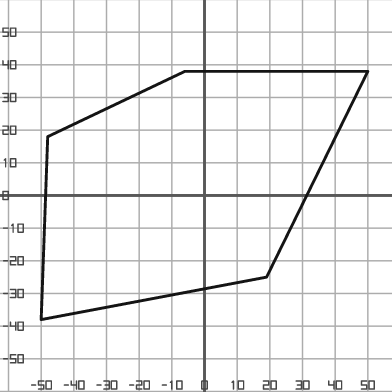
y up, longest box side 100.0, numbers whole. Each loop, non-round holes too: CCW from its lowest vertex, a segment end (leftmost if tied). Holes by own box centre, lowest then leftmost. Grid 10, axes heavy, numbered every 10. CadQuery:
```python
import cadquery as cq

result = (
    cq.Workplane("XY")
    .moveTo(-50.0, -38.0)
    .lineTo(19.0, -25.0)
    .lineTo(50.0, 38.0)
    .lineTo(-6.0, 38.0)
    .lineTo(-48.0, 18.0)
    .close()
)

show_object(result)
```